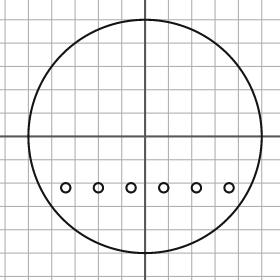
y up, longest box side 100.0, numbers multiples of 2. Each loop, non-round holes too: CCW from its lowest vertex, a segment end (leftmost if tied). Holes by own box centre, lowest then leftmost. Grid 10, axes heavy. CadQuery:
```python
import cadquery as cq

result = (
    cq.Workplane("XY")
    .moveTo(0.0, 0.0)
    .circle(50.0)
    .moveTo(-34.0, -22.0)
    .circle(2.0)
    .moveTo(-20.0, -22.0)
    .circle(2.0)
    .moveTo(-6.0, -22.0)
    .circle(2.0)
    .moveTo(8.0, -22.0)
    .circle(2.0)
    .moveTo(22.0, -22.0)
    .circle(2.0)
    .moveTo(36.0, -22.0)
    .circle(2.0)
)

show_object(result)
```